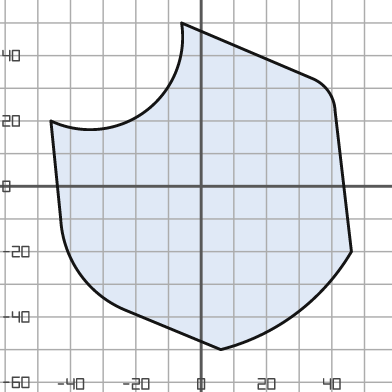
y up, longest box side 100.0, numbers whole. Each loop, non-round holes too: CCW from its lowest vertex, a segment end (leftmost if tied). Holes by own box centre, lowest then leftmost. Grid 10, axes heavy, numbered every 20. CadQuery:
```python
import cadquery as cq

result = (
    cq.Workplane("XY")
    .moveTo(6.0, -50.0)
    .threePointArc((29.0, -39.0), (46.0, -20.0))
    .lineTo(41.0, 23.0)
    .threePointArc((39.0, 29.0), (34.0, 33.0))
    .lineTo(-6.0, 50.0)
    .threePointArc((-17.0, 23.0), (-46.0, 20.0))
    .lineTo(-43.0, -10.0)
    .threePointArc((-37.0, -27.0), (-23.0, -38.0))
    .close()
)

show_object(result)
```